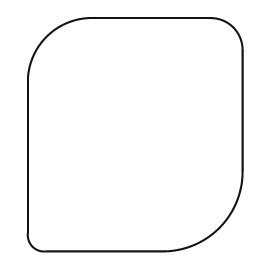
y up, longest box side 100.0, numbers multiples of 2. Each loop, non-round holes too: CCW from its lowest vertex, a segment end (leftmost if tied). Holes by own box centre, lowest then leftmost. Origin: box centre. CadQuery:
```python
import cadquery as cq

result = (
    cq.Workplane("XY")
    .moveTo(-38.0, -50.0)
    .lineTo(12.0, -50.0)
    .threePointArc((36.0, -40.0), (46.0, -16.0))
    .lineTo(46.0, 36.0)
    .threePointArc((42.0, 46.0), (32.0, 50.0))
    .lineTo(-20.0, 50.0)
    .threePointArc((-38.0, 42.0), (-46.0, 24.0))
    .lineTo(-46.0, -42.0)
    .threePointArc((-44.0, -48.0), (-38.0, -50.0))
    .close()
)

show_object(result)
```